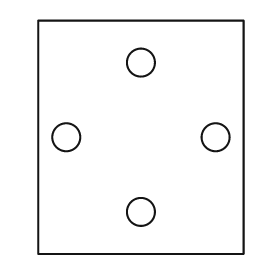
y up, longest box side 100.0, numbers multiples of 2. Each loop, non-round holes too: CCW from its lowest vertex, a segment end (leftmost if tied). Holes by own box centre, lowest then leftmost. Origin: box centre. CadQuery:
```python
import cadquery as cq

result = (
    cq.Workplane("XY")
    .moveTo(-44.0, -50.0)
    .lineTo(44.0, -50.0)
    .lineTo(44.0, 50.0)
    .lineTo(-44.0, 50.0)
    .close()
    .moveTo(0.0, -32.0)
    .circle(6.0)
    .moveTo(-32.0, 0.0)
    .circle(6.0)
    .moveTo(32.0, 0.0)
    .circle(6.0)
    .moveTo(0.0, 32.0)
    .circle(6.0)
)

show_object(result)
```